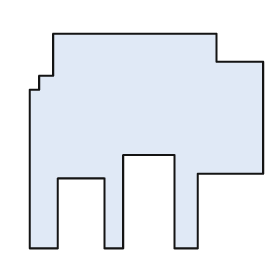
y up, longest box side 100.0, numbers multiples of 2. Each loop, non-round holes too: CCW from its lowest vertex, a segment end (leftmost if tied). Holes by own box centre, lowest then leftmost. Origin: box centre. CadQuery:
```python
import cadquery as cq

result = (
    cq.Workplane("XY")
    .moveTo(-50.0, -46.0)
    .lineTo(-38.0, -46.0)
    .lineTo(-38.0, -16.0)
    .lineTo(-18.0, -16.0)
    .lineTo(-18.0, -46.0)
    .lineTo(-10.0, -46.0)
    .lineTo(-10.0, -6.0)
    .lineTo(12.0, -6.0)
    .lineTo(12.0, -46.0)
    .lineTo(22.0, -46.0)
    .lineTo(22.0, -14.0)
    .lineTo(50.0, -14.0)
    .lineTo(50.0, 34.0)
    .lineTo(30.0, 34.0)
    .lineTo(30.0, 46.0)
    .lineTo(-40.0, 46.0)
    .lineTo(-40.0, 28.0)
    .lineTo(-46.0, 28.0)
    .lineTo(-46.0, 22.0)
    .lineTo(-50.0, 22.0)
    .close()
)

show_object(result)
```